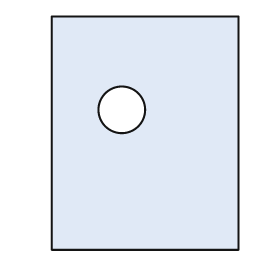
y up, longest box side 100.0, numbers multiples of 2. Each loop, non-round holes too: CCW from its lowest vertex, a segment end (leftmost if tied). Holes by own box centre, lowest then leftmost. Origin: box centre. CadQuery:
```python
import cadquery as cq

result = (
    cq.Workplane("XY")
    .moveTo(-40.0, -50.0)
    .lineTo(40.0, -50.0)
    .lineTo(40.0, 50.0)
    .lineTo(-40.0, 50.0)
    .close()
    .moveTo(-10.0, 10.0)
    .circle(10.0)
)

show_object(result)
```